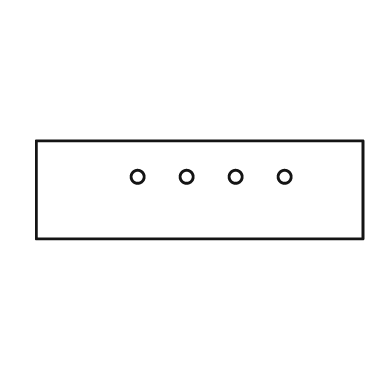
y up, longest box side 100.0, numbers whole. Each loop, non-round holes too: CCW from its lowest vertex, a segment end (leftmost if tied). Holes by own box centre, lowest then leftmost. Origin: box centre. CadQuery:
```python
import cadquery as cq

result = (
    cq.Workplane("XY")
    .moveTo(-50.0, -15.0)
    .lineTo(50.0, -15.0)
    .lineTo(50.0, 15.0)
    .lineTo(-50.0, 15.0)
    .close()
    .moveTo(-19.0, 4.0)
    .circle(2.0)
    .moveTo(-4.0, 4.0)
    .circle(2.0)
    .moveTo(11.0, 4.0)
    .circle(2.0)
    .moveTo(26.0, 4.0)
    .circle(2.0)
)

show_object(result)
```